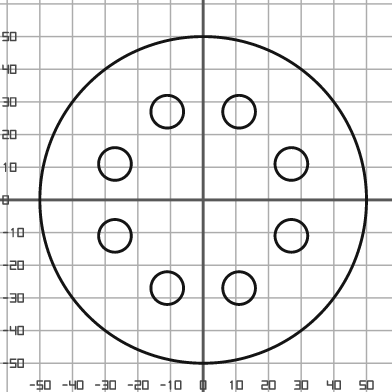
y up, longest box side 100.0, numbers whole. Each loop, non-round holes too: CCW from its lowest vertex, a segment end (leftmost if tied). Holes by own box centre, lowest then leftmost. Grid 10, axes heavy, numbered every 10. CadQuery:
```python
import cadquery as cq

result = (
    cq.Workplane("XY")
    .moveTo(0.0, 0.0)
    .circle(50.0)
    .moveTo(-11.0, -27.0)
    .circle(5.0)
    .moveTo(11.0, -27.0)
    .circle(5.0)
    .moveTo(-27.0, -11.0)
    .circle(5.0)
    .moveTo(27.0, -11.0)
    .circle(5.0)
    .moveTo(-27.0, 11.0)
    .circle(5.0)
    .moveTo(27.0, 11.0)
    .circle(5.0)
    .moveTo(-11.0, 27.0)
    .circle(5.0)
    .moveTo(11.0, 27.0)
    .circle(5.0)
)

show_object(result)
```